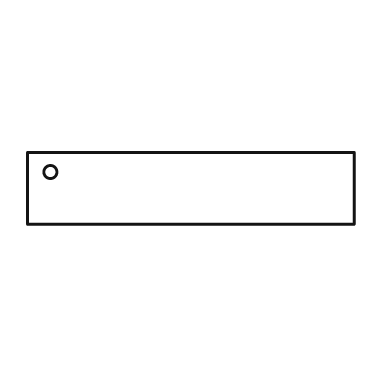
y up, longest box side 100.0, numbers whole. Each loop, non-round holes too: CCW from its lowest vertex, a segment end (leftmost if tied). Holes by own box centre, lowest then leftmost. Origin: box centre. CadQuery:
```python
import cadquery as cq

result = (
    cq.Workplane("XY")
    .moveTo(-50.0, -11.0)
    .lineTo(50.0, -11.0)
    .lineTo(50.0, 11.0)
    .lineTo(-50.0, 11.0)
    .close()
    .moveTo(-43.0, 5.0)
    .circle(2.0)
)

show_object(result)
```